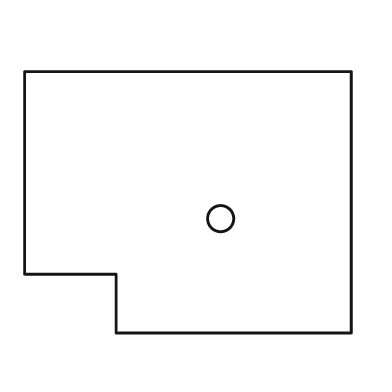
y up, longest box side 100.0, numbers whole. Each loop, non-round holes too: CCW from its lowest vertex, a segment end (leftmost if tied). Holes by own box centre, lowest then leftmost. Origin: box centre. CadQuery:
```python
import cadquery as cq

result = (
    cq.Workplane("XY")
    .moveTo(-22.0, -40.0)
    .lineTo(50.0, -40.0)
    .lineTo(50.0, 40.0)
    .lineTo(-50.0, 40.0)
    .lineTo(-50.0, -22.0)
    .lineTo(-22.0, -22.0)
    .close()
    .moveTo(10.0, -5.0)
    .circle(4.0)
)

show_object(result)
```